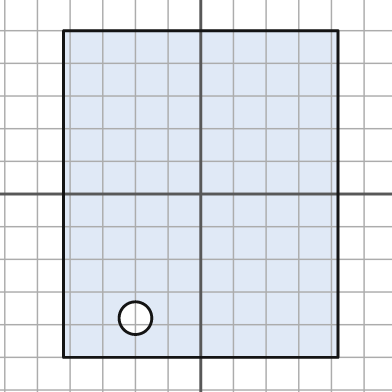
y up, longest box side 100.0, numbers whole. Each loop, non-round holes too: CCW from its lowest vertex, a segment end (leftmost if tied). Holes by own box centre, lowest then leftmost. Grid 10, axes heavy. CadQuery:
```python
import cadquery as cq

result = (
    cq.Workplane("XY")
    .moveTo(-42.0, -50.0)
    .lineTo(42.0, -50.0)
    .lineTo(42.0, 50.0)
    .lineTo(-42.0, 50.0)
    .close()
    .moveTo(-20.0, -38.0)
    .circle(5.0)
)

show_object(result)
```